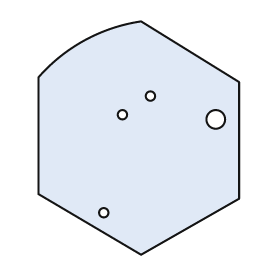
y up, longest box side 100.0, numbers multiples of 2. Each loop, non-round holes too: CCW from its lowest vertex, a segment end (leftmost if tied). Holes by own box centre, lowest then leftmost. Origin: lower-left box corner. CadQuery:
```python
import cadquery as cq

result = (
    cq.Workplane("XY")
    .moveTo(44.0, 0.0)
    .lineTo(86.0, 24.0)
    .lineTo(86.0, 74.0)
    .lineTo(44.0, 100.0)
    .threePointArc((20.0, 92.0), (0.0, 76.0))
    .lineTo(0.0, 26.0)
    .close()
    .moveTo(28.0, 18.0)
    .circle(2.0)
    .moveTo(76.0, 58.0)
    .circle(4.0)
    .moveTo(36.0, 60.0)
    .circle(2.0)
    .moveTo(48.0, 68.0)
    .circle(2.0)
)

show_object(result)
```